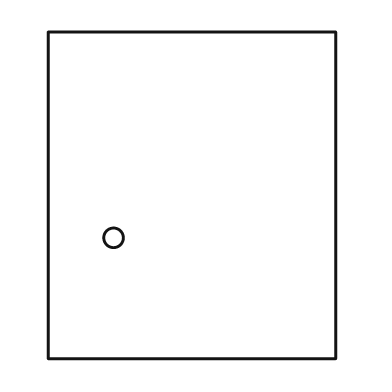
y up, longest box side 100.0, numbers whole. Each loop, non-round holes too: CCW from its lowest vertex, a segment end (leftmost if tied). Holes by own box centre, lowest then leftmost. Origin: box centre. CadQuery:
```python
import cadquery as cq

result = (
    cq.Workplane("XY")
    .moveTo(-44.0, -50.0)
    .lineTo(44.0, -50.0)
    .lineTo(44.0, 50.0)
    .lineTo(-44.0, 50.0)
    .close()
    .moveTo(-24.0, -13.0)
    .circle(3.0)
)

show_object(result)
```